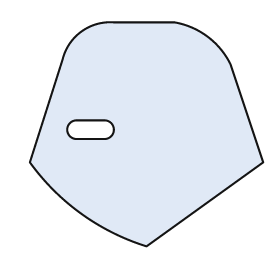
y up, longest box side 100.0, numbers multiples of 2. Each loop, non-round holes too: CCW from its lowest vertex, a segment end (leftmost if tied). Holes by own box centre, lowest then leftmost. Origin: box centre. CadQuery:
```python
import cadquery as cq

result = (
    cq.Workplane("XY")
    .moveTo(0.0, -48.0)
    .lineTo(50.0, -12.0)
    .lineTo(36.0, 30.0)
    .threePointArc((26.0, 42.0), (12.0, 48.0))
    .lineTo(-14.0, 48.0)
    .threePointArc((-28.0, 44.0), (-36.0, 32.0))
    .lineTo(-50.0, -12.0)
    .threePointArc((-28.0, -34.0), (0.0, -48.0))
    .close()
    .moveTo(-30.0, -2.0)
    .lineTo(-18.0, -2.0)
    .threePointArc((-14.0, 2.0), (-18.0, 6.0))
    .lineTo(-30.0, 6.0)
    .threePointArc((-34.0, 2.0), (-30.0, -2.0))
    .close()
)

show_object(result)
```